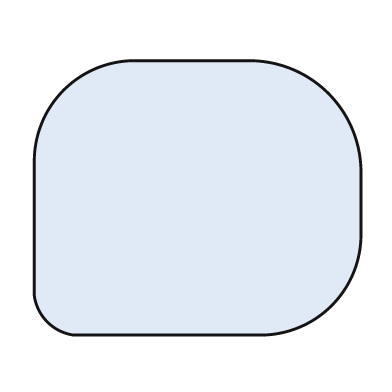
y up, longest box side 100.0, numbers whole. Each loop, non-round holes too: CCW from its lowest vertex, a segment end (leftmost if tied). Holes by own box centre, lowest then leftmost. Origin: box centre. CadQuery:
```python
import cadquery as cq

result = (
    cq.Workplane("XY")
    .moveTo(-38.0, -42.0)
    .lineTo(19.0, -42.0)
    .threePointArc((41.0, -33.0), (50.0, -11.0))
    .lineTo(50.0, 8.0)
    .threePointArc((40.0, 32.0), (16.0, 42.0))
    .lineTo(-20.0, 42.0)
    .threePointArc((-41.0, 33.0), (-50.0, 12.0))
    .lineTo(-50.0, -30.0)
    .threePointArc((-46.0, -38.0), (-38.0, -42.0))
    .close()
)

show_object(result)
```